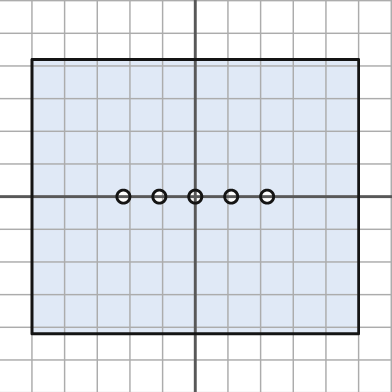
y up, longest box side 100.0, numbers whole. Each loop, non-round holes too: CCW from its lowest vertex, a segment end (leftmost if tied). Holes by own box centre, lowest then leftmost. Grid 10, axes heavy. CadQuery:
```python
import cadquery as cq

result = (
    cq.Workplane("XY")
    .moveTo(-50.0, -42.0)
    .lineTo(50.0, -42.0)
    .lineTo(50.0, 42.0)
    .lineTo(-50.0, 42.0)
    .close()
    .moveTo(-22.0, 0.0)
    .circle(2.0)
    .moveTo(-11.0, 0.0)
    .circle(2.0)
    .moveTo(0.0, 0.0)
    .circle(2.0)
    .moveTo(11.0, 0.0)
    .circle(2.0)
    .moveTo(22.0, 0.0)
    .circle(2.0)
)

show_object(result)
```